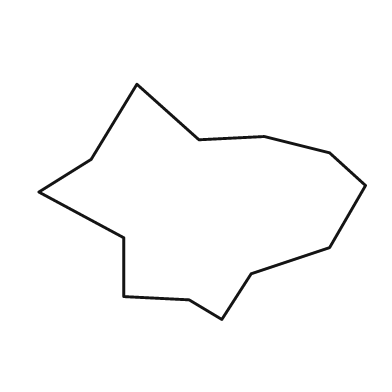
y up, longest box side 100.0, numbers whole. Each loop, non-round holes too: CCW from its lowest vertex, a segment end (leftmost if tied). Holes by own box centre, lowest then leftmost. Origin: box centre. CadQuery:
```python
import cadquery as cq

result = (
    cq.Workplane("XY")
    .moveTo(6.0, -36.0)
    .lineTo(15.0, -22.0)
    .lineTo(39.0, -14.0)
    .lineTo(50.0, 5.0)
    .lineTo(39.0, 15.0)
    .lineTo(19.0, 20.0)
    .lineTo(-1.0, 19.0)
    .lineTo(-20.0, 36.0)
    .lineTo(-34.0, 13.0)
    .lineTo(-50.0, 3.0)
    .lineTo(-24.0, -11.0)
    .lineTo(-24.0, -29.0)
    .lineTo(-4.0, -30.0)
    .close()
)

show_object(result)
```